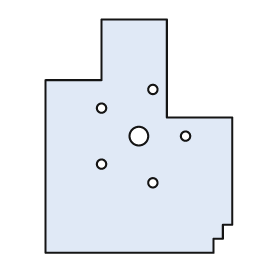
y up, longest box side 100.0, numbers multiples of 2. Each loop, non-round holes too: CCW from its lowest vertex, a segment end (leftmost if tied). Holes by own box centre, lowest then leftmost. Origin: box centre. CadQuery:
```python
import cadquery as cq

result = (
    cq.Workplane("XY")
    .moveTo(-40.0, -50.0)
    .lineTo(32.0, -50.0)
    .lineTo(32.0, -44.0)
    .lineTo(36.0, -44.0)
    .lineTo(36.0, -38.0)
    .lineTo(40.0, -38.0)
    .lineTo(40.0, 8.0)
    .lineTo(12.0, 8.0)
    .lineTo(12.0, 50.0)
    .lineTo(-16.0, 50.0)
    .lineTo(-16.0, 24.0)
    .lineTo(-40.0, 24.0)
    .close()
    .moveTo(6.0, -20.0)
    .circle(2.0)
    .moveTo(-16.0, -12.0)
    .circle(2.0)
    .moveTo(0.0, 0.0)
    .circle(4.0)
    .moveTo(20.0, 0.0)
    .circle(2.0)
    .moveTo(-16.0, 12.0)
    .circle(2.0)
    .moveTo(6.0, 20.0)
    .circle(2.0)
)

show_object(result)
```